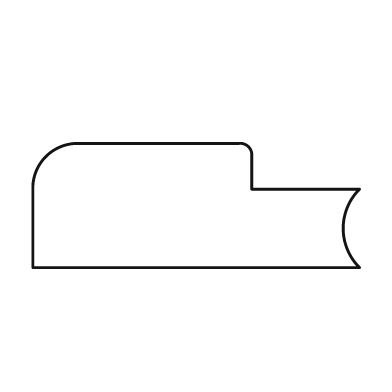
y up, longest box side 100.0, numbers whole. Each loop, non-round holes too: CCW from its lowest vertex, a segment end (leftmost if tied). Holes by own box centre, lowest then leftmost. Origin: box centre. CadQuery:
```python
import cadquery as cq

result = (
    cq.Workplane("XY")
    .moveTo(-50.0, -19.0)
    .lineTo(50.0, -19.0)
    .threePointArc((45.0, -7.0), (50.0, 5.0))
    .lineTo(17.0, 5.0)
    .lineTo(17.0, 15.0)
    .threePointArc((16.0, 18.0), (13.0, 19.0))
    .lineTo(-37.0, 19.0)
    .threePointArc((-46.0, 15.0), (-50.0, 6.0))
    .close()
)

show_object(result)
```